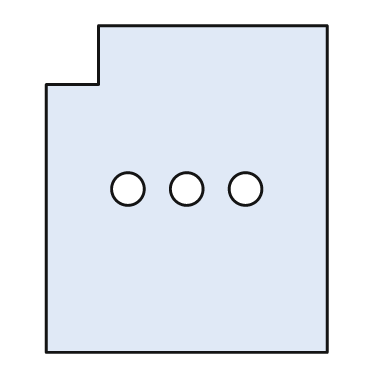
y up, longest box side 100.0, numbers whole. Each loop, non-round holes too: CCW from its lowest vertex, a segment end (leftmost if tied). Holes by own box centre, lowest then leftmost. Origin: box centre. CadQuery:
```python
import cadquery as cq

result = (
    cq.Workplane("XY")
    .moveTo(-43.0, -50.0)
    .lineTo(43.0, -50.0)
    .lineTo(43.0, 50.0)
    .lineTo(-27.0, 50.0)
    .lineTo(-27.0, 32.0)
    .lineTo(-43.0, 32.0)
    .close()
    .moveTo(-18.0, 0.0)
    .circle(5.0)
    .moveTo(0.0, 0.0)
    .circle(5.0)
    .moveTo(18.0, 0.0)
    .circle(5.0)
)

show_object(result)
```